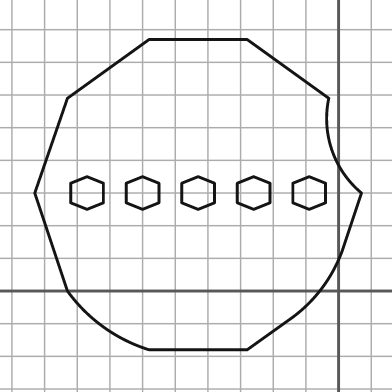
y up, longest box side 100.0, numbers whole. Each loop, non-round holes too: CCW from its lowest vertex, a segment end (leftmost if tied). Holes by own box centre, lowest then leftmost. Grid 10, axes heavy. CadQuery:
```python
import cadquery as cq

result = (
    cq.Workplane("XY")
    .moveTo(-58.0, -18.0)
    .lineTo(-28.0, -18.0)
    .lineTo(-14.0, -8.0)
    .threePointArc((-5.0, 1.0), (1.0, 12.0))
    .lineTo(7.0, 30.0)
    .threePointArc((-2.0, 43.0), (-3.0, 59.0))
    .lineTo(-28.0, 77.0)
    .lineTo(-58.0, 77.0)
    .lineTo(-83.0, 59.0)
    .lineTo(-93.0, 30.0)
    .lineTo(-83.0, 0.0)
    .threePointArc((-72.0, -11.0), (-58.0, -18.0))
    .close()
    .moveTo(-77.0, 25.0)
    .lineTo(-72.0, 27.0)
    .lineTo(-72.0, 33.0)
    .lineTo(-77.0, 35.0)
    .lineTo(-82.0, 33.0)
    .lineTo(-82.0, 27.0)
    .close()
    .moveTo(-60.0, 25.0)
    .lineTo(-55.0, 27.0)
    .lineTo(-55.0, 33.0)
    .lineTo(-60.0, 35.0)
    .lineTo(-65.0, 33.0)
    .lineTo(-65.0, 27.0)
    .close()
    .moveTo(-43.0, 25.0)
    .lineTo(-38.0, 27.0)
    .lineTo(-38.0, 33.0)
    .lineTo(-43.0, 35.0)
    .lineTo(-48.0, 33.0)
    .lineTo(-48.0, 27.0)
    .close()
    .moveTo(-26.0, 25.0)
    .lineTo(-21.0, 27.0)
    .lineTo(-21.0, 33.0)
    .lineTo(-26.0, 35.0)
    .lineTo(-31.0, 33.0)
    .lineTo(-31.0, 27.0)
    .close()
    .moveTo(-9.0, 25.0)
    .lineTo(-4.0, 27.0)
    .lineTo(-4.0, 33.0)
    .lineTo(-9.0, 35.0)
    .lineTo(-14.0, 33.0)
    .lineTo(-14.0, 27.0)
    .close()
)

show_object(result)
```